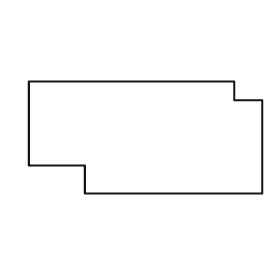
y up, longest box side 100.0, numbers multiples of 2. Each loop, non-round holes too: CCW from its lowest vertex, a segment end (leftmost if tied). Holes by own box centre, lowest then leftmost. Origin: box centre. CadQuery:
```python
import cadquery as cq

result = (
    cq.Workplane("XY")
    .moveTo(-26.0, -24.0)
    .lineTo(50.0, -24.0)
    .lineTo(50.0, 16.0)
    .lineTo(38.0, 16.0)
    .lineTo(38.0, 24.0)
    .lineTo(-50.0, 24.0)
    .lineTo(-50.0, -12.0)
    .lineTo(-26.0, -12.0)
    .close()
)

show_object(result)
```